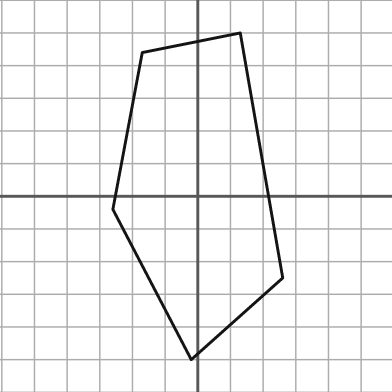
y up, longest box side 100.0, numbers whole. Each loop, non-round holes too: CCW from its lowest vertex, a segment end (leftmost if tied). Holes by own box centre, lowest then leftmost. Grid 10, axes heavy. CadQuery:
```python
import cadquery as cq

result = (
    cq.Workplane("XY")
    .moveTo(-2.0, -50.0)
    .lineTo(26.0, -25.0)
    .lineTo(13.0, 50.0)
    .lineTo(-17.0, 44.0)
    .lineTo(-26.0, -4.0)
    .close()
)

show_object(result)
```